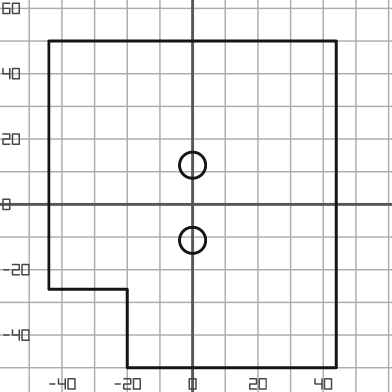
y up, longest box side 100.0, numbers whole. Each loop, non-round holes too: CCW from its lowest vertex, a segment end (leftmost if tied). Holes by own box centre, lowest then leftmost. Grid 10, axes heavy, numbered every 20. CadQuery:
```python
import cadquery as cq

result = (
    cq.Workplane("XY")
    .moveTo(-20.0, -50.0)
    .lineTo(44.0, -50.0)
    .lineTo(44.0, 50.0)
    .lineTo(-44.0, 50.0)
    .lineTo(-44.0, -26.0)
    .lineTo(-20.0, -26.0)
    .close()
    .moveTo(0.0, -11.0)
    .circle(4.0)
    .moveTo(0.0, 12.0)
    .circle(4.0)
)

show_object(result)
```